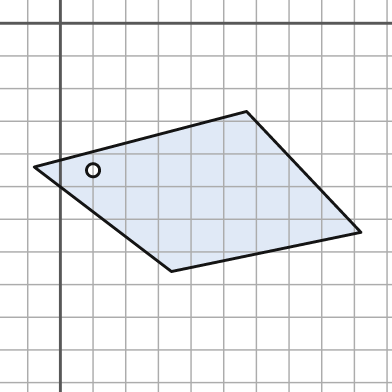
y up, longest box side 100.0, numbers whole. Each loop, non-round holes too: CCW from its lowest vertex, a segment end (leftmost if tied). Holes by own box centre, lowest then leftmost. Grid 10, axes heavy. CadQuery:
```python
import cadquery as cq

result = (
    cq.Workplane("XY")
    .moveTo(34.0, -76.0)
    .lineTo(92.0, -64.0)
    .lineTo(57.0, -27.0)
    .lineTo(-8.0, -44.0)
    .close()
    .moveTo(10.0, -45.0)
    .circle(2.0)
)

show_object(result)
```